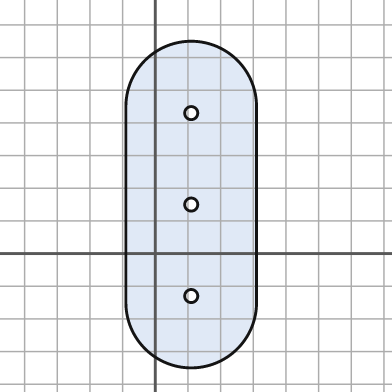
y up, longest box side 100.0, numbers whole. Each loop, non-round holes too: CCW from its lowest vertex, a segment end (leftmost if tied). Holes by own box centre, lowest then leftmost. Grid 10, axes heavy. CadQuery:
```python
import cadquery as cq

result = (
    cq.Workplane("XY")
    .moveTo(-9.0, -15.0)
    .threePointArc((11.0, -35.0), (31.0, -15.0))
    .lineTo(31.0, 45.0)
    .threePointArc((11.0, 65.0), (-9.0, 45.0))
    .close()
    .moveTo(11.0, -13.0)
    .circle(2.0)
    .moveTo(11.0, 15.0)
    .circle(2.0)
    .moveTo(11.0, 43.0)
    .circle(2.0)
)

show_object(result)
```